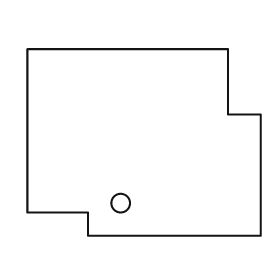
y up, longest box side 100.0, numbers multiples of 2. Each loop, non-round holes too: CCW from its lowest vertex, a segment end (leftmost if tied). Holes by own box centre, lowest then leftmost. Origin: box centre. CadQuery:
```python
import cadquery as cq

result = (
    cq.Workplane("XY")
    .moveTo(-24.0, -40.0)
    .lineTo(50.0, -40.0)
    .lineTo(50.0, 12.0)
    .lineTo(36.0, 12.0)
    .lineTo(36.0, 40.0)
    .lineTo(-50.0, 40.0)
    .lineTo(-50.0, -30.0)
    .lineTo(-24.0, -30.0)
    .close()
    .moveTo(-10.0, -26.0)
    .circle(4.0)
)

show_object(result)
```